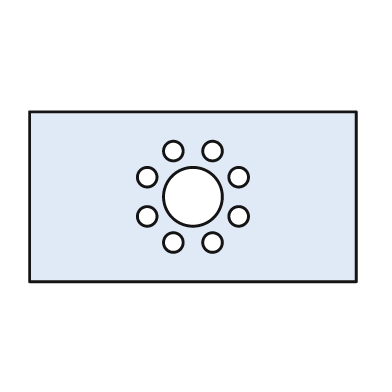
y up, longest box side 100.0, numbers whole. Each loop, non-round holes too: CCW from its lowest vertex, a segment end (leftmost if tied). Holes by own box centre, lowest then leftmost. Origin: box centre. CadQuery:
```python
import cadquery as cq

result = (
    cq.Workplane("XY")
    .moveTo(-50.0, -26.0)
    .lineTo(50.0, -26.0)
    .lineTo(50.0, 26.0)
    .lineTo(-50.0, 26.0)
    .close()
    .moveTo(-6.0, -14.0)
    .circle(3.0)
    .moveTo(6.0, -14.0)
    .circle(3.0)
    .moveTo(-14.0, -6.0)
    .circle(3.0)
    .moveTo(14.0, -6.0)
    .circle(3.0)
    .moveTo(0.0, 0.0)
    .circle(9.0)
    .moveTo(-14.0, 6.0)
    .circle(3.0)
    .moveTo(14.0, 6.0)
    .circle(3.0)
    .moveTo(-6.0, 14.0)
    .circle(3.0)
    .moveTo(6.0, 14.0)
    .circle(3.0)
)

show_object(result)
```